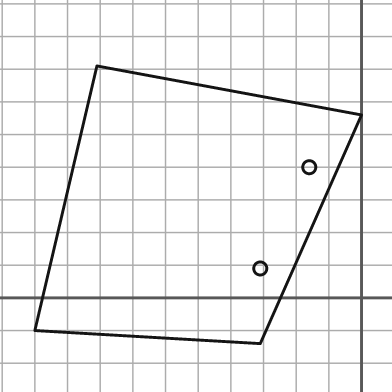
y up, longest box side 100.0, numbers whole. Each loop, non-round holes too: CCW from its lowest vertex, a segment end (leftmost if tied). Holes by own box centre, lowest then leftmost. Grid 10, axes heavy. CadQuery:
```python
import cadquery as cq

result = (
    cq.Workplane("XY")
    .moveTo(-31.0, -14.0)
    .lineTo(0.0, 56.0)
    .lineTo(-81.0, 71.0)
    .lineTo(-100.0, -10.0)
    .close()
    .moveTo(-31.0, 9.0)
    .circle(2.0)
    .moveTo(-16.0, 40.0)
    .circle(2.0)
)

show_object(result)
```